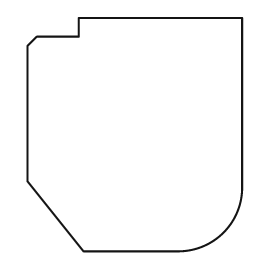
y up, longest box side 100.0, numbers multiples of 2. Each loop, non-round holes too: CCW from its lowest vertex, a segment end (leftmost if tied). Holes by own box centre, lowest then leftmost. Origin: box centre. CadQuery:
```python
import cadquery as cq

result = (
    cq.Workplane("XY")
    .moveTo(-22.0, -50.0)
    .lineTo(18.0, -50.0)
    .threePointArc((38.0, -42.0), (46.0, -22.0))
    .lineTo(46.0, 50.0)
    .lineTo(-24.0, 50.0)
    .lineTo(-24.0, 42.0)
    .lineTo(-42.0, 42.0)
    .lineTo(-46.0, 38.0)
    .lineTo(-46.0, -20.0)
    .close()
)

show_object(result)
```